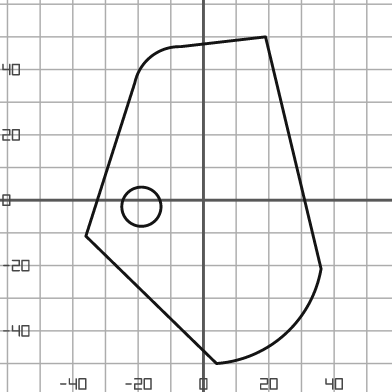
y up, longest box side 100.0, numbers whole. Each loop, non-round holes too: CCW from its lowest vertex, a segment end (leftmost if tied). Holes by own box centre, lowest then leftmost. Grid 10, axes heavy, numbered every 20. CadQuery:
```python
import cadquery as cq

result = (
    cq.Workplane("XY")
    .moveTo(4.0, -50.0)
    .threePointArc((25.0, -41.0), (36.0, -21.0))
    .lineTo(19.0, 50.0)
    .lineTo(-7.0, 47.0)
    .threePointArc((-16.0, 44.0), (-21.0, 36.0))
    .lineTo(-36.0, -11.0)
    .close()
    .moveTo(-19.0, -2.0)
    .circle(6.0)
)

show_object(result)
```